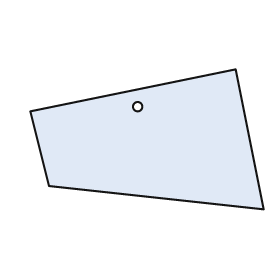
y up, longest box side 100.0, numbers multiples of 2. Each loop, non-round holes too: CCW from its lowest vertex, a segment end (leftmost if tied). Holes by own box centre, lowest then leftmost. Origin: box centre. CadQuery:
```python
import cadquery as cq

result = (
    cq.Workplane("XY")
    .moveTo(50.0, -30.0)
    .lineTo(38.0, 30.0)
    .lineTo(-50.0, 12.0)
    .lineTo(-42.0, -20.0)
    .close()
    .moveTo(-4.0, 14.0)
    .circle(2.0)
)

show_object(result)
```